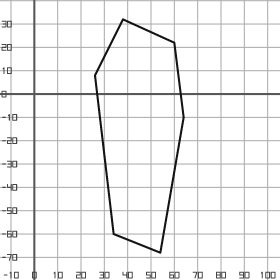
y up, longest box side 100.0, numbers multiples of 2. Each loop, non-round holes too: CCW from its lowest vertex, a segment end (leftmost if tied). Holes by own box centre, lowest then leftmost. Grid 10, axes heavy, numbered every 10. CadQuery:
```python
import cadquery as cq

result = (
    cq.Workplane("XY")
    .moveTo(54.0, -68.0)
    .lineTo(64.0, -10.0)
    .lineTo(60.0, 22.0)
    .lineTo(38.0, 32.0)
    .lineTo(26.0, 8.0)
    .lineTo(34.0, -60.0)
    .close()
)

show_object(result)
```